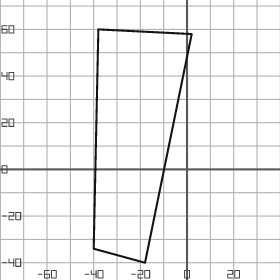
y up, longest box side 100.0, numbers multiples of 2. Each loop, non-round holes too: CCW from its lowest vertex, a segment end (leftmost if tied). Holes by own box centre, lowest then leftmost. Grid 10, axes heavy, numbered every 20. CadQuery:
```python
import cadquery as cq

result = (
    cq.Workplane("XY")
    .moveTo(-18.0, -40.0)
    .lineTo(2.0, 58.0)
    .lineTo(-38.0, 60.0)
    .lineTo(-40.0, -34.0)
    .close()
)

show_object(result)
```